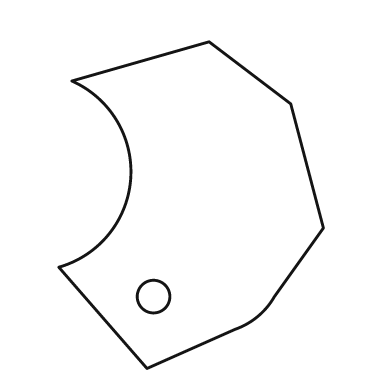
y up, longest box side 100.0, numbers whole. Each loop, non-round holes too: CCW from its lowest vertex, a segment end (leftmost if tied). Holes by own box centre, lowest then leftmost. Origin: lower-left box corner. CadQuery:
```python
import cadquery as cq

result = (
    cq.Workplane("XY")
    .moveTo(27.0, 0.0)
    .lineTo(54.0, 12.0)
    .threePointArc((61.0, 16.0), (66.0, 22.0))
    .lineTo(81.0, 43.0)
    .lineTo(71.0, 81.0)
    .lineTo(46.0, 100.0)
    .lineTo(4.0, 88.0)
    .threePointArc((22.0, 58.0), (0.0, 31.0))
    .close()
    .moveTo(29.0, 22.0)
    .circle(5.0)
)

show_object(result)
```